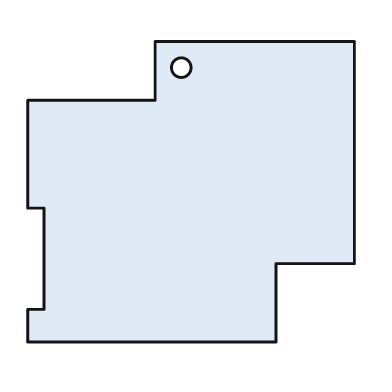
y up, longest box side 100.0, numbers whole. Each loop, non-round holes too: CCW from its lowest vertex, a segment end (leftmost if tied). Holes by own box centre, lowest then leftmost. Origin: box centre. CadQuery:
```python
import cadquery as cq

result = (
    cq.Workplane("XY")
    .moveTo(-50.0, -46.0)
    .lineTo(26.0, -46.0)
    .lineTo(26.0, -22.0)
    .lineTo(50.0, -22.0)
    .lineTo(50.0, 46.0)
    .lineTo(-11.0, 46.0)
    .lineTo(-11.0, 28.0)
    .lineTo(-50.0, 28.0)
    .lineTo(-50.0, -5.0)
    .lineTo(-45.0, -5.0)
    .lineTo(-45.0, -36.0)
    .lineTo(-50.0, -36.0)
    .close()
    .moveTo(-3.0, 38.0)
    .circle(3.0)
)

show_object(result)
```